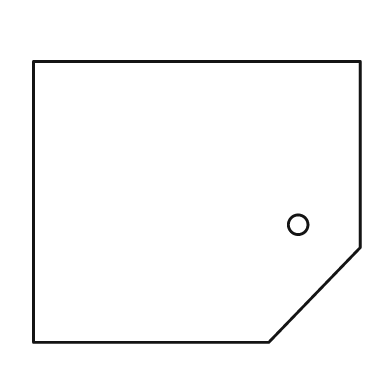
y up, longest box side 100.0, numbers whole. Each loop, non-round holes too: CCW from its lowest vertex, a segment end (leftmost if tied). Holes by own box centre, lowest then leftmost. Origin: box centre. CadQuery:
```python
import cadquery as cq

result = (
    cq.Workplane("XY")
    .moveTo(-50.0, -43.0)
    .lineTo(22.0, -43.0)
    .lineTo(50.0, -14.0)
    .lineTo(50.0, 43.0)
    .lineTo(-50.0, 43.0)
    .close()
    .moveTo(31.0, -7.0)
    .circle(3.0)
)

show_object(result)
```